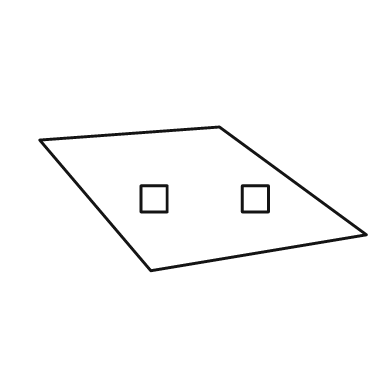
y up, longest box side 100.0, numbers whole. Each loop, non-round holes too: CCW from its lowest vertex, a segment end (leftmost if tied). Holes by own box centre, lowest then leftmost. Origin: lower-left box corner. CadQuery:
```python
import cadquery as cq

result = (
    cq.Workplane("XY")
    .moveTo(34.0, 0.0)
    .lineTo(100.0, 11.0)
    .lineTo(55.0, 44.0)
    .lineTo(0.0, 40.0)
    .close()
    .moveTo(31.0, 18.0)
    .lineTo(39.0, 18.0)
    .lineTo(39.0, 26.0)
    .lineTo(31.0, 26.0)
    .close()
    .moveTo(62.0, 18.0)
    .lineTo(70.0, 18.0)
    .lineTo(70.0, 26.0)
    .lineTo(62.0, 26.0)
    .close()
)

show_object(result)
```